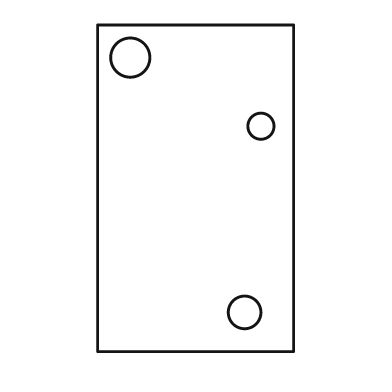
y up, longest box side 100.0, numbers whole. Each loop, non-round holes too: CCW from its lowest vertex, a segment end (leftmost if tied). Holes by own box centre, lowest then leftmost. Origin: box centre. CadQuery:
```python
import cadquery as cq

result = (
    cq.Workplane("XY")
    .moveTo(-30.0, -50.0)
    .lineTo(30.0, -50.0)
    .lineTo(30.0, 50.0)
    .lineTo(-30.0, 50.0)
    .close()
    .moveTo(15.0, -38.0)
    .circle(5.0)
    .moveTo(20.0, 19.0)
    .circle(4.0)
    .moveTo(-20.0, 40.0)
    .circle(6.0)
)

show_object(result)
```